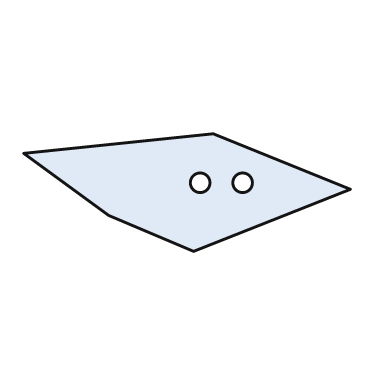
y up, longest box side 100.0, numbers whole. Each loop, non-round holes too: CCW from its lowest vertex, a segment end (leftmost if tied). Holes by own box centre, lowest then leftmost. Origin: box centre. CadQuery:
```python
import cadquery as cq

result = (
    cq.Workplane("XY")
    .moveTo(2.0, -18.0)
    .lineTo(50.0, 1.0)
    .lineTo(8.0, 18.0)
    .lineTo(-50.0, 12.0)
    .lineTo(-24.0, -7.0)
    .close()
    .moveTo(4.0, 3.0)
    .circle(3.0)
    .moveTo(17.0, 3.0)
    .circle(3.0)
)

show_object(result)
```